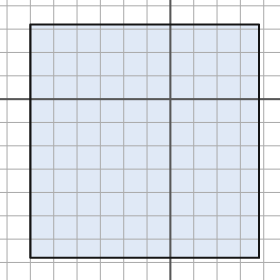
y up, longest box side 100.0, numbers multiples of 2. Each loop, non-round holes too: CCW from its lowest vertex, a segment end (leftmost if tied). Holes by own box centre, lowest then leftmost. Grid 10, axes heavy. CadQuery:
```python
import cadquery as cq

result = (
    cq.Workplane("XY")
    .moveTo(-60.0, -68.0)
    .lineTo(38.0, -68.0)
    .lineTo(38.0, 32.0)
    .lineTo(-60.0, 32.0)
    .close()
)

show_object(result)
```